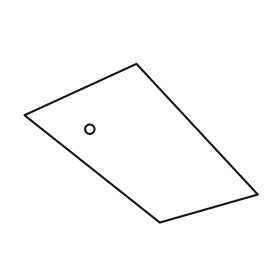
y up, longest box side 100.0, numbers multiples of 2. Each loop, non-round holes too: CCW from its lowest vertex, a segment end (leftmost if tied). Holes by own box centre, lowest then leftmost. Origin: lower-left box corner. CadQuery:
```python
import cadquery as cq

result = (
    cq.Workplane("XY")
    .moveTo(58.0, 0.0)
    .lineTo(100.0, 12.0)
    .lineTo(48.0, 68.0)
    .lineTo(0.0, 46.0)
    .close()
    .moveTo(28.0, 40.0)
    .circle(2.0)
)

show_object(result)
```